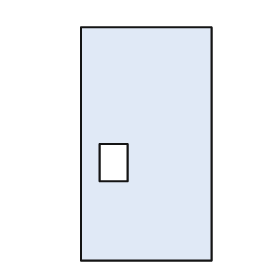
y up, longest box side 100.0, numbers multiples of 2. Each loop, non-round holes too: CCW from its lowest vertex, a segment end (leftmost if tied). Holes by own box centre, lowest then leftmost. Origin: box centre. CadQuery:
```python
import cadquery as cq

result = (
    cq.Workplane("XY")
    .moveTo(-28.0, -50.0)
    .lineTo(28.0, -50.0)
    .lineTo(28.0, 50.0)
    .lineTo(-28.0, 50.0)
    .close()
    .moveTo(-20.0, -16.0)
    .lineTo(-8.0, -16.0)
    .lineTo(-8.0, 0.0)
    .lineTo(-20.0, 0.0)
    .close()
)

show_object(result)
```